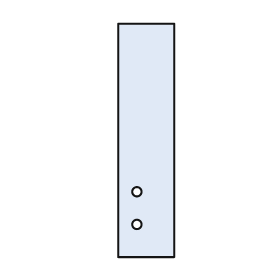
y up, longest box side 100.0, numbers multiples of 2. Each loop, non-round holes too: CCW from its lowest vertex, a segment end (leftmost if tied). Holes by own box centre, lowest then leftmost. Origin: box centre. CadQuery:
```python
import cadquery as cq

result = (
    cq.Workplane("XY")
    .moveTo(-12.0, -50.0)
    .lineTo(12.0, -50.0)
    .lineTo(12.0, 50.0)
    .lineTo(-12.0, 50.0)
    .close()
    .moveTo(-4.0, -36.0)
    .circle(2.0)
    .moveTo(-4.0, -22.0)
    .circle(2.0)
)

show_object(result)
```